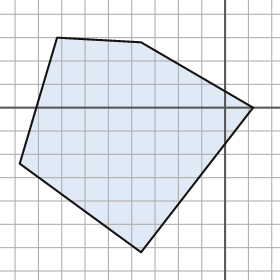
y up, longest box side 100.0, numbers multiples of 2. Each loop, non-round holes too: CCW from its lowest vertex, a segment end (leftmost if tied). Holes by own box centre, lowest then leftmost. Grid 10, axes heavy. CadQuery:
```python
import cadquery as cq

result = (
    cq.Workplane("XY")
    .moveTo(-36.0, -62.0)
    .lineTo(12.0, 0.0)
    .lineTo(-36.0, 28.0)
    .lineTo(-72.0, 30.0)
    .lineTo(-88.0, -24.0)
    .close()
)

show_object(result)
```